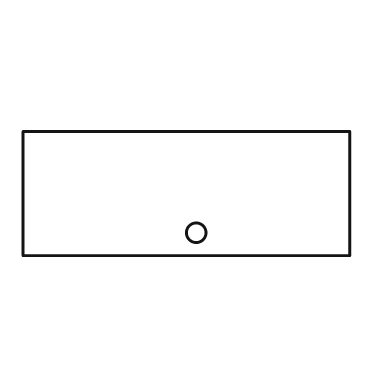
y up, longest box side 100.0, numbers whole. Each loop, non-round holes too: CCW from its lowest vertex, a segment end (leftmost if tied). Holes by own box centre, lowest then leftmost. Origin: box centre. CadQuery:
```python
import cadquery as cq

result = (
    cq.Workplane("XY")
    .moveTo(-50.0, -19.0)
    .lineTo(50.0, -19.0)
    .lineTo(50.0, 19.0)
    .lineTo(-50.0, 19.0)
    .close()
    .moveTo(3.0, -12.0)
    .circle(3.0)
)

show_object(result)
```